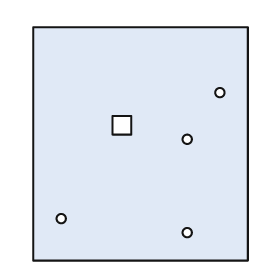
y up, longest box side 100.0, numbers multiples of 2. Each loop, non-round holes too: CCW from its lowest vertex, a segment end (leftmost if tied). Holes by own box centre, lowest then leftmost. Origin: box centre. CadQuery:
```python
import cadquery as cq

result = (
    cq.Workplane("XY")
    .moveTo(-46.0, -50.0)
    .lineTo(46.0, -50.0)
    .lineTo(46.0, 50.0)
    .lineTo(-46.0, 50.0)
    .close()
    .moveTo(20.0, -38.0)
    .circle(2.0)
    .moveTo(-34.0, -32.0)
    .circle(2.0)
    .moveTo(20.0, 2.0)
    .circle(2.0)
    .moveTo(-12.0, 4.0)
    .lineTo(-4.0, 4.0)
    .lineTo(-4.0, 12.0)
    .lineTo(-12.0, 12.0)
    .close()
    .moveTo(34.0, 22.0)
    .circle(2.0)
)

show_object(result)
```